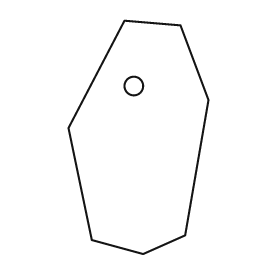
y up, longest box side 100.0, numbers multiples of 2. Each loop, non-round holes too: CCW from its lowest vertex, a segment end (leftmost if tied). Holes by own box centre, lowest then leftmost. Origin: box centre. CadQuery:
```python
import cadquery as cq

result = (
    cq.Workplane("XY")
    .moveTo(2.0, -50.0)
    .lineTo(20.0, -42.0)
    .lineTo(30.0, 16.0)
    .lineTo(18.0, 48.0)
    .lineTo(-6.0, 50.0)
    .lineTo(-30.0, 4.0)
    .lineTo(-20.0, -44.0)
    .close()
    .moveTo(-2.0, 22.0)
    .circle(4.0)
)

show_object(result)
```